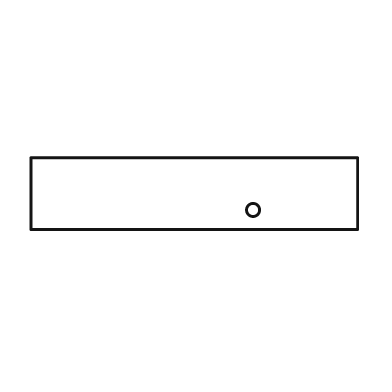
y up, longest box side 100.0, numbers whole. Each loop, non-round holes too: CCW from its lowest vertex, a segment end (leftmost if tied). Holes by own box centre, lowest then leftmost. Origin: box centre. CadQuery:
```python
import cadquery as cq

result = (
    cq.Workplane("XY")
    .moveTo(-50.0, -11.0)
    .lineTo(50.0, -11.0)
    .lineTo(50.0, 11.0)
    .lineTo(-50.0, 11.0)
    .close()
    .moveTo(18.0, -5.0)
    .circle(2.0)
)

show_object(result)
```